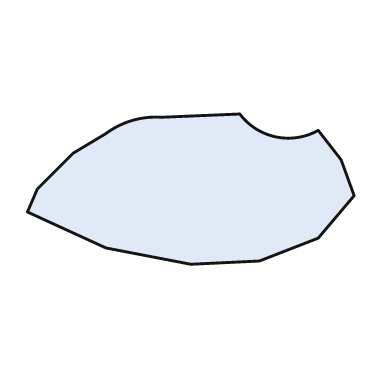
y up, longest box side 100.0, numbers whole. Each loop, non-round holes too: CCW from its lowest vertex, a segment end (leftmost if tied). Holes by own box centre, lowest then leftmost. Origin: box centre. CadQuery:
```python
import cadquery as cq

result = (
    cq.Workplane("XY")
    .moveTo(0.0, -23.0)
    .lineTo(21.0, -22.0)
    .lineTo(39.0, -15.0)
    .lineTo(50.0, -2.0)
    .lineTo(46.0, 9.0)
    .lineTo(39.0, 18.0)
    .threePointArc((26.0, 16.0), (15.0, 23.0))
    .lineTo(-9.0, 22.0)
    .threePointArc((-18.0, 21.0), (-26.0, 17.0))
    .lineTo(-36.0, 11.0)
    .lineTo(-47.0, 0.0)
    .lineTo(-50.0, -7.0)
    .lineTo(-26.0, -18.0)
    .close()
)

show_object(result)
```